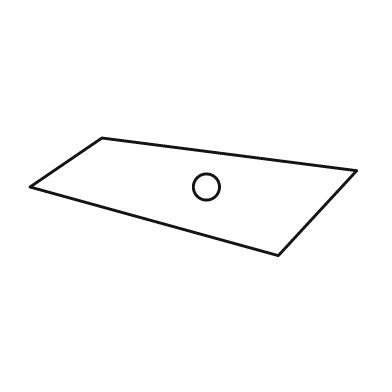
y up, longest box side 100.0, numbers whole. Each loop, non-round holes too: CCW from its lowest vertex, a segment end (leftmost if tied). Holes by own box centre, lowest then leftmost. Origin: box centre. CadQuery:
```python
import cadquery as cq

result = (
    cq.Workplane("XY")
    .moveTo(26.0, -18.0)
    .lineTo(50.0, 8.0)
    .lineTo(-28.0, 18.0)
    .lineTo(-50.0, 3.0)
    .close()
    .moveTo(4.0, 3.0)
    .circle(4.0)
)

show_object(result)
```